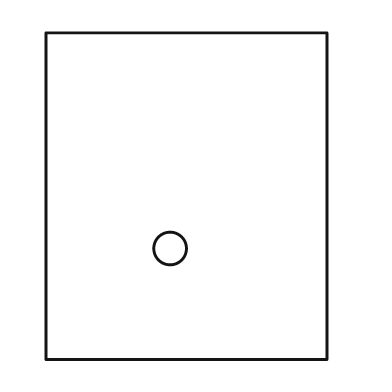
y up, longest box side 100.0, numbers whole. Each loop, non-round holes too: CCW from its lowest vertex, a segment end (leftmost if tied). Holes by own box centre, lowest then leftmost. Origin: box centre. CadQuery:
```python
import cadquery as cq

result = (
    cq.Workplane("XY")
    .moveTo(-43.0, -50.0)
    .lineTo(43.0, -50.0)
    .lineTo(43.0, 50.0)
    .lineTo(-43.0, 50.0)
    .close()
    .moveTo(-5.0, -16.0)
    .circle(5.0)
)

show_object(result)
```